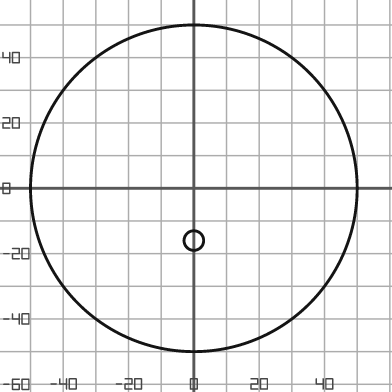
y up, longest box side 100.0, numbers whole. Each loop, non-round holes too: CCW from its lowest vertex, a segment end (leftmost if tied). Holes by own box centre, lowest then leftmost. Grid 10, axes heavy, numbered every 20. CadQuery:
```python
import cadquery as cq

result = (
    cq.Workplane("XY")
    .moveTo(0.0, 0.0)
    .circle(50.0)
    .moveTo(0.0, -16.0)
    .circle(3.0)
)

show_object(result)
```